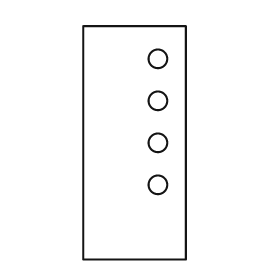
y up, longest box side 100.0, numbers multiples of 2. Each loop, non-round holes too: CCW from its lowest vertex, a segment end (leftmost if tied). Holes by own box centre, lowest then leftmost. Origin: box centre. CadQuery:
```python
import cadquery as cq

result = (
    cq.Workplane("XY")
    .moveTo(-22.0, -50.0)
    .lineTo(22.0, -50.0)
    .lineTo(22.0, 50.0)
    .lineTo(-22.0, 50.0)
    .close()
    .moveTo(10.0, -18.0)
    .circle(4.0)
    .moveTo(10.0, 0.0)
    .circle(4.0)
    .moveTo(10.0, 18.0)
    .circle(4.0)
    .moveTo(10.0, 36.0)
    .circle(4.0)
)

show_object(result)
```